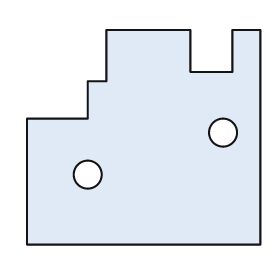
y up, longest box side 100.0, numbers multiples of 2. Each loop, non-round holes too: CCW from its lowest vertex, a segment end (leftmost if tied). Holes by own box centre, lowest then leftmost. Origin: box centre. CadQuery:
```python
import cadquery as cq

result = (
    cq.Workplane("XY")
    .moveTo(-50.0, -46.0)
    .lineTo(50.0, -46.0)
    .lineTo(50.0, 46.0)
    .lineTo(38.0, 46.0)
    .lineTo(38.0, 28.0)
    .lineTo(20.0, 28.0)
    .lineTo(20.0, 46.0)
    .lineTo(-16.0, 46.0)
    .lineTo(-16.0, 24.0)
    .lineTo(-24.0, 24.0)
    .lineTo(-24.0, 8.0)
    .lineTo(-50.0, 8.0)
    .close()
    .moveTo(-24.0, -16.0)
    .circle(6.0)
    .moveTo(34.0, 2.0)
    .circle(6.0)
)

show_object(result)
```